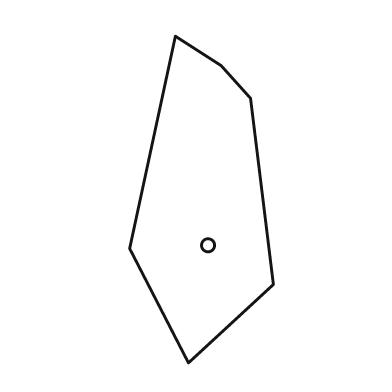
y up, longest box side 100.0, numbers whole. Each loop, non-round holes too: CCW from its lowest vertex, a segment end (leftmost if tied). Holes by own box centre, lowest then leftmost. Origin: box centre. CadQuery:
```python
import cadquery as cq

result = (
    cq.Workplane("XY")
    .moveTo(-4.0, -50.0)
    .lineTo(22.0, -26.0)
    .lineTo(15.0, 31.0)
    .lineTo(6.0, 41.0)
    .lineTo(-8.0, 50.0)
    .lineTo(-22.0, -15.0)
    .close()
    .moveTo(2.0, -14.0)
    .circle(2.0)
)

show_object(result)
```